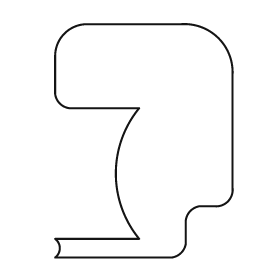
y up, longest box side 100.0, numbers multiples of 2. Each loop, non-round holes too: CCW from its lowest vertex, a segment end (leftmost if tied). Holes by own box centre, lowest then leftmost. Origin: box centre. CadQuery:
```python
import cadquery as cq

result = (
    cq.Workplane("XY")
    .moveTo(-38.0, -50.0)
    .lineTo(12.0, -50.0)
    .threePointArc((16.0, -48.0), (18.0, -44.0))
    .lineTo(18.0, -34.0)
    .threePointArc((20.0, -30.0), (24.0, -28.0))
    .lineTo(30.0, -28.0)
    .threePointArc((36.0, -26.0), (38.0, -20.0))
    .lineTo(38.0, 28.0)
    .threePointArc((32.0, 44.0), (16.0, 50.0))
    .lineTo(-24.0, 50.0)
    .threePointArc((-34.0, 46.0), (-38.0, 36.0))
    .lineTo(-38.0, 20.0)
    .threePointArc((-36.0, 16.0), (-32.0, 14.0))
    .lineTo(-2.0, 14.0)
    .threePointArc((-12.0, -14.0), (-2.0, -42.0))
    .lineTo(-38.0, -42.0)
    .threePointArc((-36.0, -46.0), (-38.0, -50.0))
    .close()
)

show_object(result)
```